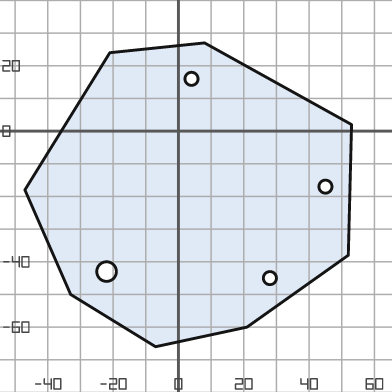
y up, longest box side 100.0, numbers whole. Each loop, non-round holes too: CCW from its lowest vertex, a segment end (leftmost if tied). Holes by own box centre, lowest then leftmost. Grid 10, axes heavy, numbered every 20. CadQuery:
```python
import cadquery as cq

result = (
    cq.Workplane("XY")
    .moveTo(-7.0, -66.0)
    .lineTo(21.0, -60.0)
    .lineTo(52.0, -38.0)
    .lineTo(53.0, 2.0)
    .lineTo(8.0, 27.0)
    .lineTo(-21.0, 24.0)
    .lineTo(-47.0, -18.0)
    .lineTo(-33.0, -50.0)
    .close()
    .moveTo(28.0, -45.0)
    .circle(2.0)
    .moveTo(-22.0, -43.0)
    .circle(3.0)
    .moveTo(45.0, -17.0)
    .circle(2.0)
    .moveTo(4.0, 16.0)
    .circle(2.0)
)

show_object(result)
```